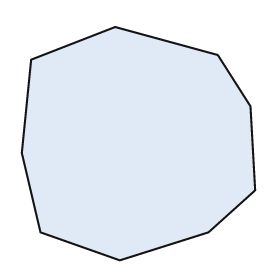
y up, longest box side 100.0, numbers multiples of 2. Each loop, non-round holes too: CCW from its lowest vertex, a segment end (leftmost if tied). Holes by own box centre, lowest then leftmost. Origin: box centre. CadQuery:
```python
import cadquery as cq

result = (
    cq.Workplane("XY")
    .moveTo(-8.0, -50.0)
    .lineTo(30.0, -38.0)
    .lineTo(50.0, -20.0)
    .lineTo(48.0, 16.0)
    .lineTo(34.0, 38.0)
    .lineTo(-10.0, 50.0)
    .lineTo(-46.0, 36.0)
    .lineTo(-50.0, -4.0)
    .lineTo(-42.0, -38.0)
    .close()
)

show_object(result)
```